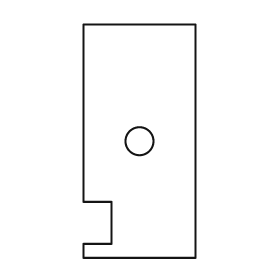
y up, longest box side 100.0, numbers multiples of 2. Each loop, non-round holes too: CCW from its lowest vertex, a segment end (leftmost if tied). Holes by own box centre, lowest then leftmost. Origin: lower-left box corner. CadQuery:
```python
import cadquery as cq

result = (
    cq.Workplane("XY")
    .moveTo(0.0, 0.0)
    .lineTo(48.0, 0.0)
    .lineTo(48.0, 100.0)
    .lineTo(0.0, 100.0)
    .lineTo(0.0, 24.0)
    .lineTo(12.0, 24.0)
    .lineTo(12.0, 6.0)
    .lineTo(0.0, 6.0)
    .close()
    .moveTo(24.0, 50.0)
    .circle(6.0)
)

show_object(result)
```